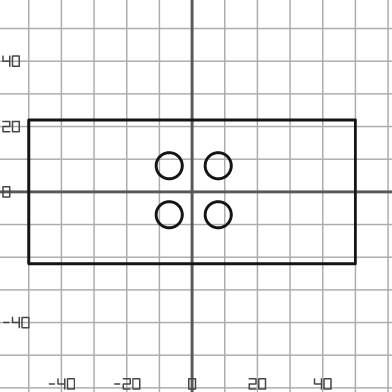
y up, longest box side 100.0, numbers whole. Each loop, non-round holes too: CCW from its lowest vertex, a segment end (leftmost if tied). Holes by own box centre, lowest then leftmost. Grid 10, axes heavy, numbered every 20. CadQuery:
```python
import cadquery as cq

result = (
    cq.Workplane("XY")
    .moveTo(-50.0, -22.0)
    .lineTo(50.0, -22.0)
    .lineTo(50.0, 22.0)
    .lineTo(-50.0, 22.0)
    .close()
    .moveTo(-7.0, -7.0)
    .circle(4.0)
    .moveTo(8.0, -7.0)
    .circle(4.0)
    .moveTo(-7.0, 8.0)
    .circle(4.0)
    .moveTo(8.0, 8.0)
    .circle(4.0)
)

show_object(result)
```